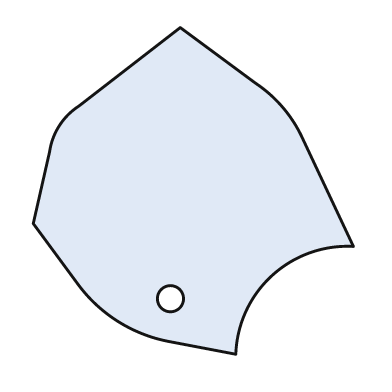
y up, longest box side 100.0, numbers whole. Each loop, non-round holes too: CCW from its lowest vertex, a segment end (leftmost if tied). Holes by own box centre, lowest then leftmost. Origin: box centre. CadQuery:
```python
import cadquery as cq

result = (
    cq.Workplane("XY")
    .moveTo(13.0, -50.0)
    .threePointArc((24.0, -26.0), (49.0, -17.0))
    .lineTo(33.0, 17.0)
    .threePointArc((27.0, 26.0), (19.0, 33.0))
    .lineTo(-4.0, 50.0)
    .lineTo(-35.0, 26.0)
    .threePointArc((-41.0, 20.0), (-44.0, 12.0))
    .lineTo(-49.0, -10.0)
    .lineTo(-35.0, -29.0)
    .threePointArc((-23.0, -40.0), (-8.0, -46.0))
    .close()
    .moveTo(-7.0, -33.0)
    .circle(4.0)
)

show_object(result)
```